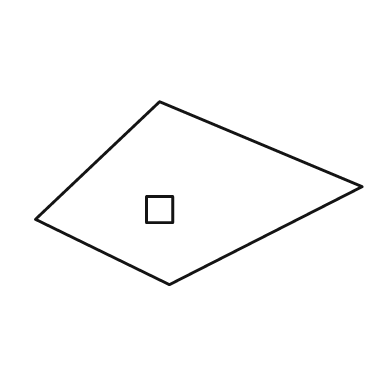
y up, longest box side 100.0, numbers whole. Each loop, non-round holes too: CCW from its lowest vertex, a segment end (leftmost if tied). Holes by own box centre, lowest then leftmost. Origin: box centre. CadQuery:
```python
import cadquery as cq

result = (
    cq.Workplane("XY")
    .moveTo(-9.0, -28.0)
    .lineTo(50.0, 2.0)
    .lineTo(-12.0, 28.0)
    .lineTo(-50.0, -8.0)
    .close()
    .moveTo(-16.0, -9.0)
    .lineTo(-8.0, -9.0)
    .lineTo(-8.0, -1.0)
    .lineTo(-16.0, -1.0)
    .close()
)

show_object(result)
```